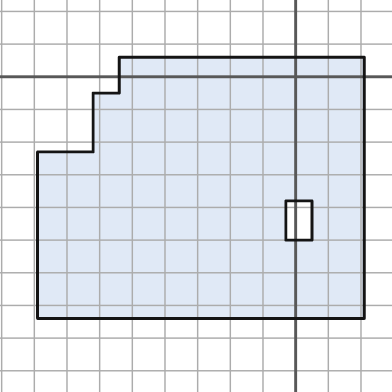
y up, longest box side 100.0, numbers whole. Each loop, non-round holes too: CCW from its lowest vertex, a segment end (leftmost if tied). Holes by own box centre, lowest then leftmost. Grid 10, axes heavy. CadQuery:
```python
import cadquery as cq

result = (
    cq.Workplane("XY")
    .moveTo(-79.0, -74.0)
    .lineTo(21.0, -74.0)
    .lineTo(21.0, 6.0)
    .lineTo(-54.0, 6.0)
    .lineTo(-54.0, -5.0)
    .lineTo(-62.0, -5.0)
    .lineTo(-62.0, -23.0)
    .lineTo(-79.0, -23.0)
    .close()
    .moveTo(-3.0, -50.0)
    .lineTo(5.0, -50.0)
    .lineTo(5.0, -38.0)
    .lineTo(-3.0, -38.0)
    .close()
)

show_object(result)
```